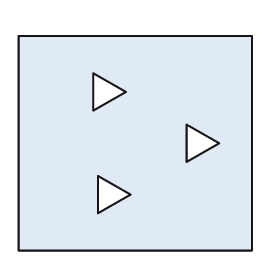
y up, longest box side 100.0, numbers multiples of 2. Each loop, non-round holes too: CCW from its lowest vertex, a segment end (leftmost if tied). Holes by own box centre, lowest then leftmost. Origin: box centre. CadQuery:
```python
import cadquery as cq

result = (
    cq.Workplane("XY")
    .moveTo(-50.0, -46.0)
    .lineTo(50.0, -46.0)
    .lineTo(50.0, 46.0)
    .lineTo(-50.0, 46.0)
    .close()
    .moveTo(-16.0, -30.0)
    .lineTo(-2.0, -22.0)
    .lineTo(-16.0, -14.0)
    .close()
    .moveTo(22.0, -8.0)
    .lineTo(36.0, 0.0)
    .lineTo(22.0, 8.0)
    .close()
    .moveTo(-18.0, 14.0)
    .lineTo(-4.0, 22.0)
    .lineTo(-18.0, 30.0)
    .close()
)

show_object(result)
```